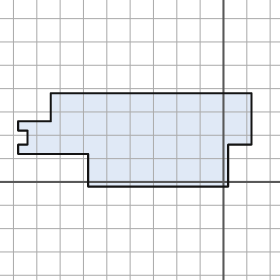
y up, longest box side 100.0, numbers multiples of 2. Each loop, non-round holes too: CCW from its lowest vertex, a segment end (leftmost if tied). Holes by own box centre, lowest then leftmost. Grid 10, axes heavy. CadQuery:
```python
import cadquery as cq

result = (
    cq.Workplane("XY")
    .moveTo(-58.0, -2.0)
    .lineTo(2.0, -2.0)
    .lineTo(2.0, 16.0)
    .lineTo(12.0, 16.0)
    .lineTo(12.0, 38.0)
    .lineTo(-74.0, 38.0)
    .lineTo(-74.0, 26.0)
    .lineTo(-88.0, 26.0)
    .lineTo(-88.0, 22.0)
    .lineTo(-84.0, 22.0)
    .lineTo(-84.0, 16.0)
    .lineTo(-88.0, 16.0)
    .lineTo(-88.0, 12.0)
    .lineTo(-58.0, 12.0)
    .close()
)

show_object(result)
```